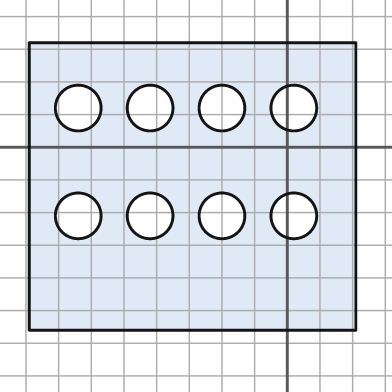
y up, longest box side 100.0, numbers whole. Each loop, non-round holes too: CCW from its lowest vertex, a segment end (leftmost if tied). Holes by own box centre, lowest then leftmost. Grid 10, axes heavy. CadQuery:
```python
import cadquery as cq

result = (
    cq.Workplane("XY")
    .moveTo(-79.0, -56.0)
    .lineTo(21.0, -56.0)
    .lineTo(21.0, 32.0)
    .lineTo(-79.0, 32.0)
    .close()
    .moveTo(-64.0, -21.0)
    .circle(7.0)
    .moveTo(-42.0, -21.0)
    .circle(7.0)
    .moveTo(-20.0, -21.0)
    .circle(7.0)
    .moveTo(2.0, -21.0)
    .circle(7.0)
    .moveTo(-64.0, 12.0)
    .circle(7.0)
    .moveTo(-42.0, 12.0)
    .circle(7.0)
    .moveTo(-20.0, 12.0)
    .circle(7.0)
    .moveTo(2.0, 12.0)
    .circle(7.0)
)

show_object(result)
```